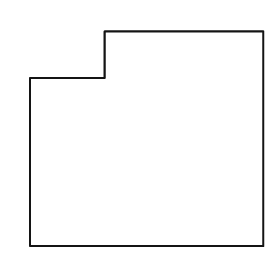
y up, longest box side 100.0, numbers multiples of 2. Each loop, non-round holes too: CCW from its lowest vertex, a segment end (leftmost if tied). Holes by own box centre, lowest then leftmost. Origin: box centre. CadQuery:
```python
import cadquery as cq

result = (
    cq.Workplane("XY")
    .moveTo(-50.0, -46.0)
    .lineTo(50.0, -46.0)
    .lineTo(50.0, 46.0)
    .lineTo(-18.0, 46.0)
    .lineTo(-18.0, 26.0)
    .lineTo(-50.0, 26.0)
    .close()
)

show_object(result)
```